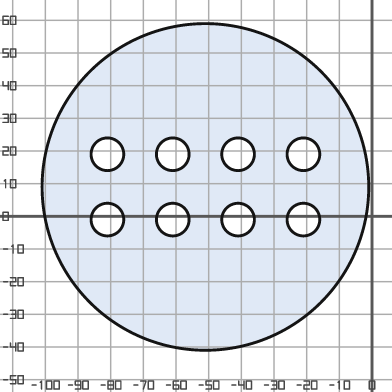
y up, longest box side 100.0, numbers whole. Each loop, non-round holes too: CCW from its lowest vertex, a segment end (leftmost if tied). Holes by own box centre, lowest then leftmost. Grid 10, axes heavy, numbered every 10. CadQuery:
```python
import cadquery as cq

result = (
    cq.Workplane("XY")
    .moveTo(-51.0, 9.0)
    .circle(50.0)
    .moveTo(-81.0, -1.0)
    .circle(5.0)
    .moveTo(-61.0, -1.0)
    .circle(5.0)
    .moveTo(-41.0, -1.0)
    .circle(5.0)
    .moveTo(-21.0, -1.0)
    .circle(5.0)
    .moveTo(-81.0, 19.0)
    .circle(5.0)
    .moveTo(-61.0, 19.0)
    .circle(5.0)
    .moveTo(-41.0, 19.0)
    .circle(5.0)
    .moveTo(-21.0, 19.0)
    .circle(5.0)
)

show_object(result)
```